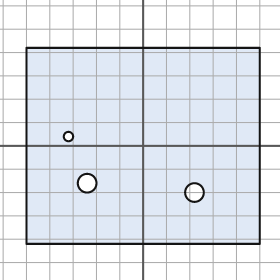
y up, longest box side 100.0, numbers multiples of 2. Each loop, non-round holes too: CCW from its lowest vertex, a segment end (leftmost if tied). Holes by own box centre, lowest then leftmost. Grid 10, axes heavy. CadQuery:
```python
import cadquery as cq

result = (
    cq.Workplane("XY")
    .moveTo(-50.0, -42.0)
    .lineTo(50.0, -42.0)
    .lineTo(50.0, 42.0)
    .lineTo(-50.0, 42.0)
    .close()
    .moveTo(22.0, -20.0)
    .circle(4.0)
    .moveTo(-24.0, -16.0)
    .circle(4.0)
    .moveTo(-32.0, 4.0)
    .circle(2.0)
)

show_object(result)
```